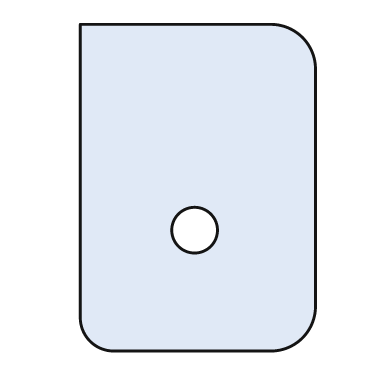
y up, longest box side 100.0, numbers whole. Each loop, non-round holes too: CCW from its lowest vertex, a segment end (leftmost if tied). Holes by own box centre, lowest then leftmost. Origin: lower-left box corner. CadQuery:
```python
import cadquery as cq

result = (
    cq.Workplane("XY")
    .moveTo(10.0, 0.0)
    .lineTo(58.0, 0.0)
    .threePointArc((68.0, 4.0), (72.0, 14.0))
    .lineTo(72.0, 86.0)
    .threePointArc((68.0, 96.0), (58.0, 100.0))
    .lineTo(0.0, 100.0)
    .lineTo(0.0, 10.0)
    .threePointArc((3.0, 3.0), (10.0, 0.0))
    .close()
    .moveTo(35.0, 37.0)
    .circle(7.0)
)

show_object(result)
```